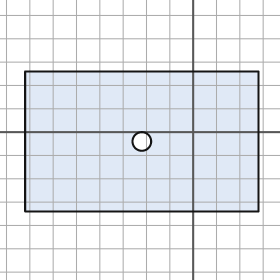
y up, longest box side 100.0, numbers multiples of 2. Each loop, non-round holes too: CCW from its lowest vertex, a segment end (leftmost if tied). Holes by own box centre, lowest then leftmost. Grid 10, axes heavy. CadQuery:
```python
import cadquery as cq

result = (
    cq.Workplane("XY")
    .moveTo(-72.0, -34.0)
    .lineTo(28.0, -34.0)
    .lineTo(28.0, 26.0)
    .lineTo(-72.0, 26.0)
    .close()
    .moveTo(-22.0, -4.0)
    .circle(4.0)
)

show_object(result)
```